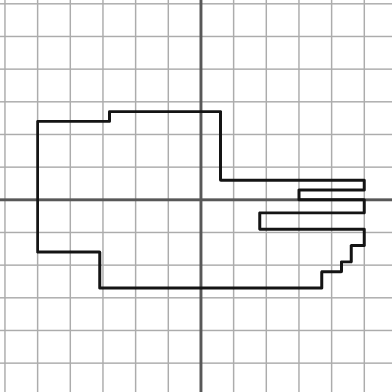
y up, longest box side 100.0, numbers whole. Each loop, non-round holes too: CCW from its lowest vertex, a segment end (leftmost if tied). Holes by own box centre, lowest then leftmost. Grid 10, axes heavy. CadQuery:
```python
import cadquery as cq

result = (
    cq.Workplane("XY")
    .moveTo(-31.0, -27.0)
    .lineTo(37.0, -27.0)
    .lineTo(37.0, -22.0)
    .lineTo(43.0, -22.0)
    .lineTo(43.0, -19.0)
    .lineTo(46.0, -19.0)
    .lineTo(46.0, -14.0)
    .lineTo(50.0, -14.0)
    .lineTo(50.0, -9.0)
    .lineTo(18.0, -9.0)
    .lineTo(18.0, -4.0)
    .lineTo(50.0, -4.0)
    .lineTo(50.0, 0.0)
    .lineTo(30.0, 0.0)
    .lineTo(30.0, 3.0)
    .lineTo(50.0, 3.0)
    .lineTo(50.0, 6.0)
    .lineTo(6.0, 6.0)
    .lineTo(6.0, 27.0)
    .lineTo(-28.0, 27.0)
    .lineTo(-28.0, 24.0)
    .lineTo(-50.0, 24.0)
    .lineTo(-50.0, -16.0)
    .lineTo(-31.0, -16.0)
    .close()
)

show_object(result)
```